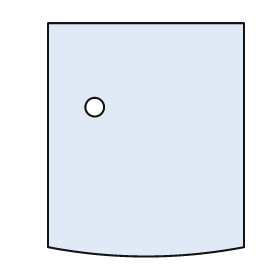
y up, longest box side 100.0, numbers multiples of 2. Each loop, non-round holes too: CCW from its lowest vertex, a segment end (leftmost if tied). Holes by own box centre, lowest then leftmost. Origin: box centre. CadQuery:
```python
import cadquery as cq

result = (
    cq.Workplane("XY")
    .moveTo(-42.0, -46.0)
    .threePointArc((0.0, -50.0), (42.0, -46.0))
    .lineTo(42.0, 50.0)
    .lineTo(-42.0, 50.0)
    .close()
    .moveTo(-22.0, 14.0)
    .circle(4.0)
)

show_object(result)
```